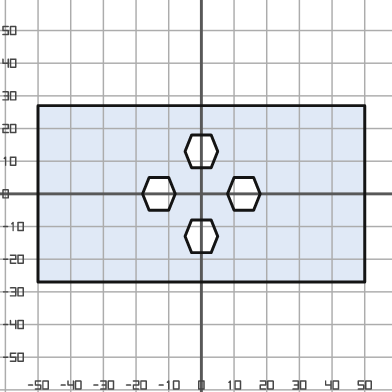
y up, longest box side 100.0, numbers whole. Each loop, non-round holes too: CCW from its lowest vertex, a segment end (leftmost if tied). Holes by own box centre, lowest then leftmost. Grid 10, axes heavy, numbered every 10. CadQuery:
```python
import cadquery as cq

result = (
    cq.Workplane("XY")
    .moveTo(-50.0, -27.0)
    .lineTo(50.0, -27.0)
    .lineTo(50.0, 27.0)
    .lineTo(-50.0, 27.0)
    .close()
    .moveTo(-3.0, -18.0)
    .lineTo(3.0, -18.0)
    .lineTo(5.0, -13.0)
    .lineTo(3.0, -8.0)
    .lineTo(-3.0, -8.0)
    .lineTo(-5.0, -13.0)
    .close()
    .moveTo(-16.0, -5.0)
    .lineTo(-10.0, -5.0)
    .lineTo(-8.0, 0.0)
    .lineTo(-10.0, 5.0)
    .lineTo(-16.0, 5.0)
    .lineTo(-18.0, 0.0)
    .close()
    .moveTo(10.0, -5.0)
    .lineTo(16.0, -5.0)
    .lineTo(18.0, 0.0)
    .lineTo(16.0, 5.0)
    .lineTo(10.0, 5.0)
    .lineTo(8.0, 0.0)
    .close()
    .moveTo(-3.0, 8.0)
    .lineTo(3.0, 8.0)
    .lineTo(5.0, 13.0)
    .lineTo(3.0, 18.0)
    .lineTo(-3.0, 18.0)
    .lineTo(-5.0, 13.0)
    .close()
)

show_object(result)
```